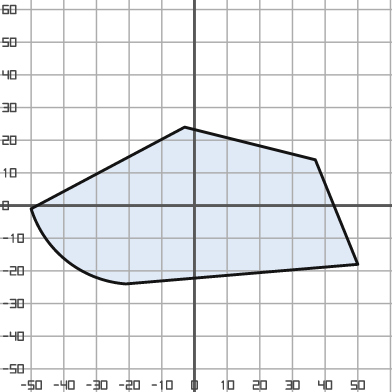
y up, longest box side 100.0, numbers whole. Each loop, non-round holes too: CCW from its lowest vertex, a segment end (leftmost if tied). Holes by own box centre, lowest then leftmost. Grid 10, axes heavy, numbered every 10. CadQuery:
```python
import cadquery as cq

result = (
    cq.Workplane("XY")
    .moveTo(-21.0, -24.0)
    .lineTo(50.0, -18.0)
    .lineTo(37.0, 14.0)
    .lineTo(-3.0, 24.0)
    .lineTo(-50.0, -1.0)
    .threePointArc((-39.0, -17.0), (-21.0, -24.0))
    .close()
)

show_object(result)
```